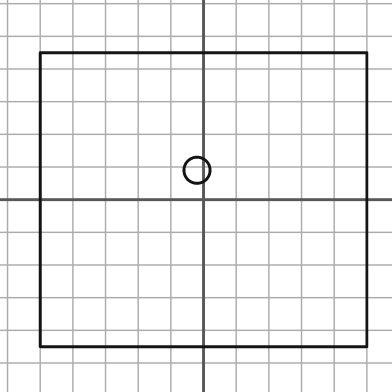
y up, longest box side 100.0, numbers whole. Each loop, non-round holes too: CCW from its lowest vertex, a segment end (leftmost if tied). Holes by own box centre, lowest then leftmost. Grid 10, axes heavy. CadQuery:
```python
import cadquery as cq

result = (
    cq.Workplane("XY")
    .moveTo(-50.0, -45.0)
    .lineTo(50.0, -45.0)
    .lineTo(50.0, 45.0)
    .lineTo(-50.0, 45.0)
    .close()
    .moveTo(-2.0, 9.0)
    .circle(4.0)
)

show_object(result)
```